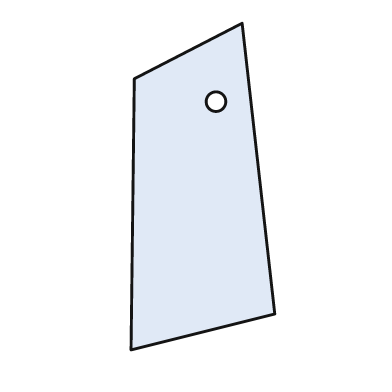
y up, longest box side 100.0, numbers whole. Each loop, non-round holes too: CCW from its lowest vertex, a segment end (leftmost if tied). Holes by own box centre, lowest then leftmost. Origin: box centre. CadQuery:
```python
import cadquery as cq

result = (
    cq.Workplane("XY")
    .moveTo(-22.0, -50.0)
    .lineTo(22.0, -39.0)
    .lineTo(12.0, 50.0)
    .lineTo(-21.0, 33.0)
    .close()
    .moveTo(4.0, 26.0)
    .circle(3.0)
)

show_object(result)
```